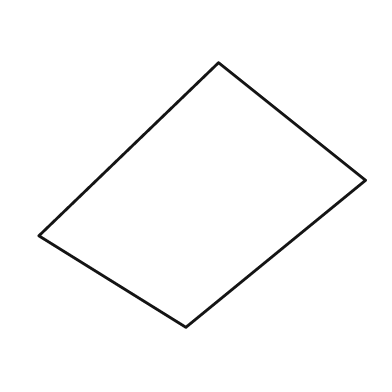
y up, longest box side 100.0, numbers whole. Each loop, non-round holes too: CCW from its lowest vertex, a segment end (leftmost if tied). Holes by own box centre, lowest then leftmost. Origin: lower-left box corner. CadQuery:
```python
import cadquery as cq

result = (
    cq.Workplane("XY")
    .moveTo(45.0, 0.0)
    .lineTo(100.0, 45.0)
    .lineTo(55.0, 81.0)
    .lineTo(0.0, 28.0)
    .close()
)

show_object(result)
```